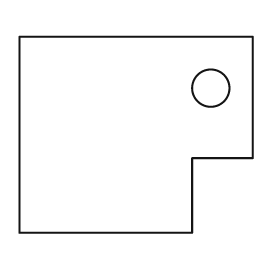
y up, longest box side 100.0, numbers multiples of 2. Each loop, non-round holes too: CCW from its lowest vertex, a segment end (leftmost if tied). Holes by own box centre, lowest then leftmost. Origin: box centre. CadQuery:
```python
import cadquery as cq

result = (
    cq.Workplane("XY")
    .moveTo(-50.0, -42.0)
    .lineTo(24.0, -42.0)
    .lineTo(24.0, -10.0)
    .lineTo(50.0, -10.0)
    .lineTo(50.0, 42.0)
    .lineTo(-50.0, 42.0)
    .close()
    .moveTo(32.0, 20.0)
    .circle(8.0)
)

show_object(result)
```